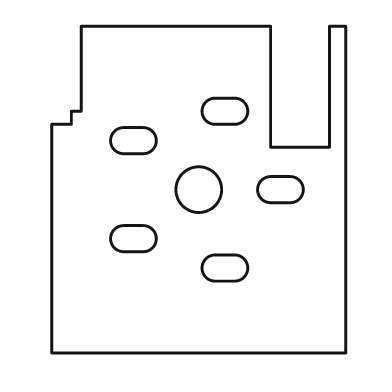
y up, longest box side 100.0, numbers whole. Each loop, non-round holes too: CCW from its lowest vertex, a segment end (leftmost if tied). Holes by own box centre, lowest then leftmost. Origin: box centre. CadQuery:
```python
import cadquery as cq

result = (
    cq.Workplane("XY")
    .moveTo(-45.0, -50.0)
    .lineTo(45.0, -50.0)
    .lineTo(45.0, 50.0)
    .lineTo(40.0, 50.0)
    .lineTo(40.0, 13.0)
    .lineTo(22.0, 13.0)
    .lineTo(22.0, 50.0)
    .lineTo(-36.0, 50.0)
    .lineTo(-36.0, 24.0)
    .lineTo(-39.0, 24.0)
    .lineTo(-39.0, 20.0)
    .lineTo(-45.0, 20.0)
    .close()
    .moveTo(5.0, -28.0)
    .lineTo(11.0, -28.0)
    .threePointArc((15.0, -24.0), (11.0, -20.0))
    .lineTo(5.0, -20.0)
    .threePointArc((1.0, -24.0), (5.0, -28.0))
    .close()
    .moveTo(-23.0, -19.0)
    .lineTo(-17.0, -19.0)
    .threePointArc((-13.0, -15.0), (-17.0, -11.0))
    .lineTo(-23.0, -11.0)
    .threePointArc((-27.0, -15.0), (-23.0, -19.0))
    .close()
    .moveTo(0.0, 0.0)
    .circle(7.0)
    .moveTo(22.0, -4.0)
    .lineTo(28.0, -4.0)
    .threePointArc((32.0, 0.0), (28.0, 4.0))
    .lineTo(22.0, 4.0)
    .threePointArc((18.0, 0.0), (22.0, -4.0))
    .close()
    .moveTo(-23.0, 11.0)
    .lineTo(-17.0, 11.0)
    .threePointArc((-13.0, 15.0), (-17.0, 19.0))
    .lineTo(-23.0, 19.0)
    .threePointArc((-27.0, 15.0), (-23.0, 11.0))
    .close()
    .moveTo(5.0, 20.0)
    .lineTo(11.0, 20.0)
    .threePointArc((15.0, 24.0), (11.0, 28.0))
    .lineTo(5.0, 28.0)
    .threePointArc((1.0, 24.0), (5.0, 20.0))
    .close()
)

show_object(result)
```